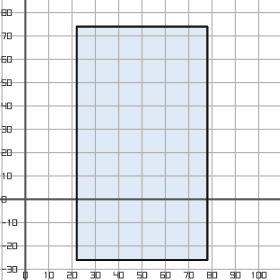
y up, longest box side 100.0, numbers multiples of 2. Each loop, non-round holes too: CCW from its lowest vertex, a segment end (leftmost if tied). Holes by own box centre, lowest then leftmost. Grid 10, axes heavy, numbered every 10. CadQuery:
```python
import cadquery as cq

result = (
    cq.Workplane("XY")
    .moveTo(22.0, -26.0)
    .lineTo(78.0, -26.0)
    .lineTo(78.0, 74.0)
    .lineTo(22.0, 74.0)
    .close()
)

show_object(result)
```